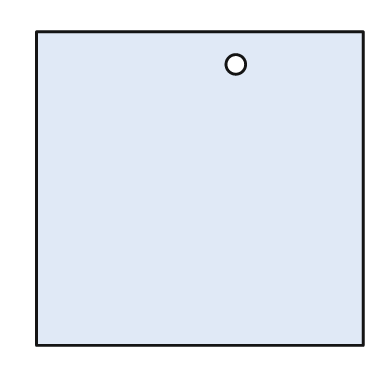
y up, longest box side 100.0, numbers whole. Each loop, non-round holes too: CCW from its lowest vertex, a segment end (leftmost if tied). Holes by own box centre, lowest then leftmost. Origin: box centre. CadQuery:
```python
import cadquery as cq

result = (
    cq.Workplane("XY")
    .moveTo(-50.0, -48.0)
    .lineTo(50.0, -48.0)
    .lineTo(50.0, 48.0)
    .lineTo(-50.0, 48.0)
    .close()
    .moveTo(11.0, 38.0)
    .circle(3.0)
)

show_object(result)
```